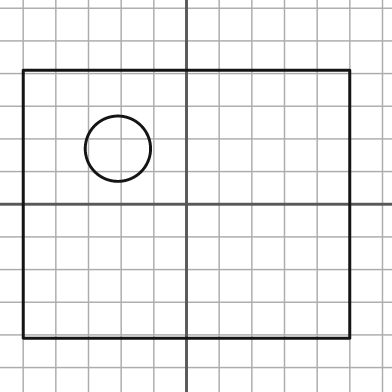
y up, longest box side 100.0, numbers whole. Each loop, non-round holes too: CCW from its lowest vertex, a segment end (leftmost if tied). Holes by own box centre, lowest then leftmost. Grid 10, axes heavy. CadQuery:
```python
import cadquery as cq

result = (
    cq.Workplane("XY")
    .moveTo(-50.0, -41.0)
    .lineTo(50.0, -41.0)
    .lineTo(50.0, 41.0)
    .lineTo(-50.0, 41.0)
    .close()
    .moveTo(-21.0, 17.0)
    .circle(10.0)
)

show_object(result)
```